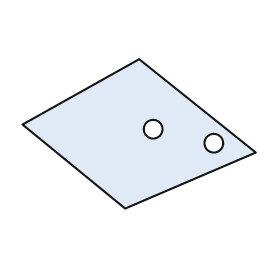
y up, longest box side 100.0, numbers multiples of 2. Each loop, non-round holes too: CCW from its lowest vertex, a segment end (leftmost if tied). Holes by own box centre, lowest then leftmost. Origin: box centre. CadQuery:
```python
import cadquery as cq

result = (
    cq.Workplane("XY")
    .moveTo(-6.0, -32.0)
    .lineTo(50.0, -8.0)
    .lineTo(0.0, 32.0)
    .lineTo(-50.0, 4.0)
    .close()
    .moveTo(32.0, -4.0)
    .circle(4.0)
    .moveTo(6.0, 2.0)
    .circle(4.0)
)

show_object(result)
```